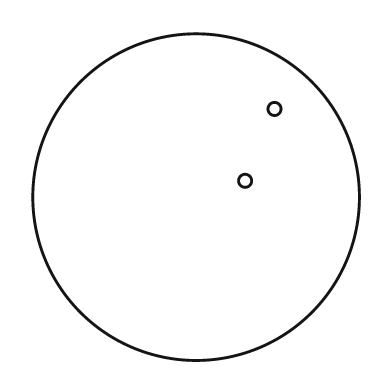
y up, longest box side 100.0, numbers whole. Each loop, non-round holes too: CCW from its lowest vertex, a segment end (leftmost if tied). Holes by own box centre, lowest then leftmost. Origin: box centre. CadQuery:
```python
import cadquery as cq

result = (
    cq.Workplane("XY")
    .moveTo(0.0, 0.0)
    .circle(50.0)
    .moveTo(15.0, 5.0)
    .circle(2.0)
    .moveTo(24.0, 27.0)
    .circle(2.0)
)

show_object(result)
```